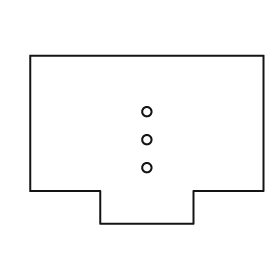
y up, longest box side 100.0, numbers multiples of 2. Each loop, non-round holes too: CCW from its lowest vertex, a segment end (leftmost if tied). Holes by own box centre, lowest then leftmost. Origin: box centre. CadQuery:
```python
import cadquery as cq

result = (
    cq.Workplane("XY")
    .moveTo(-20.0, -36.0)
    .lineTo(20.0, -36.0)
    .lineTo(20.0, -22.0)
    .lineTo(50.0, -22.0)
    .lineTo(50.0, 36.0)
    .lineTo(-50.0, 36.0)
    .lineTo(-50.0, -22.0)
    .lineTo(-20.0, -22.0)
    .close()
    .moveTo(0.0, -12.0)
    .circle(2.0)
    .moveTo(0.0, 0.0)
    .circle(2.0)
    .moveTo(0.0, 12.0)
    .circle(2.0)
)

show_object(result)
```